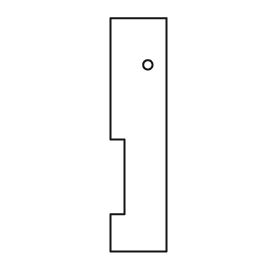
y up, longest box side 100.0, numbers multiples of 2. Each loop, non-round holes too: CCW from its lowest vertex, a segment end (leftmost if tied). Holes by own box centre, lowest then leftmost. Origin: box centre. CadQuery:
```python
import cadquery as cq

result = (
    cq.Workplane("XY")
    .moveTo(-12.0, -50.0)
    .lineTo(12.0, -50.0)
    .lineTo(12.0, 50.0)
    .lineTo(-12.0, 50.0)
    .lineTo(-12.0, -2.0)
    .lineTo(-6.0, -2.0)
    .lineTo(-6.0, -34.0)
    .lineTo(-12.0, -34.0)
    .close()
    .moveTo(4.0, 30.0)
    .circle(2.0)
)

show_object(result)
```